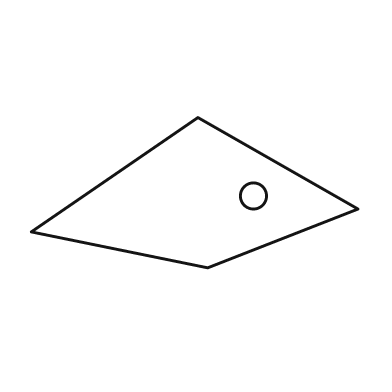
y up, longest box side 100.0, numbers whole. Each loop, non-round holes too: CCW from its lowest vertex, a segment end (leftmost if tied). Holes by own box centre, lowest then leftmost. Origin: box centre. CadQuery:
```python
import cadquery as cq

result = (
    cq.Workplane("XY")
    .moveTo(4.0, -23.0)
    .lineTo(50.0, -5.0)
    .lineTo(1.0, 23.0)
    .lineTo(-50.0, -12.0)
    .close()
    .moveTo(18.0, -1.0)
    .circle(4.0)
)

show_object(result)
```